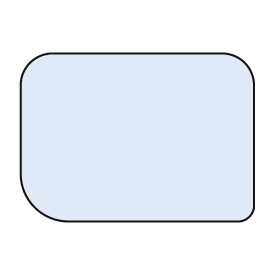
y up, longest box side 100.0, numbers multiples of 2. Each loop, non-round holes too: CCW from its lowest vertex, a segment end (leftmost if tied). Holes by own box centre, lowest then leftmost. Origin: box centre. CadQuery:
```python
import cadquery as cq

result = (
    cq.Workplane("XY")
    .moveTo(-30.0, -36.0)
    .lineTo(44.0, -36.0)
    .threePointArc((48.0, -34.0), (50.0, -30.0))
    .lineTo(50.0, 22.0)
    .threePointArc((46.0, 32.0), (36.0, 36.0))
    .lineTo(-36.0, 36.0)
    .threePointArc((-46.0, 32.0), (-50.0, 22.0))
    .lineTo(-50.0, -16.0)
    .threePointArc((-44.0, -30.0), (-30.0, -36.0))
    .close()
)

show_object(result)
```